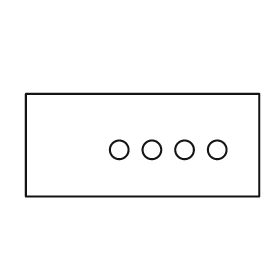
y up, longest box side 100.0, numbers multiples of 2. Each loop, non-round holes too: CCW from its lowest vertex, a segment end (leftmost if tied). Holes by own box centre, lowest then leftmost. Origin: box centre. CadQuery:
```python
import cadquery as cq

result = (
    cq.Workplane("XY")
    .moveTo(-50.0, -22.0)
    .lineTo(50.0, -22.0)
    .lineTo(50.0, 22.0)
    .lineTo(-50.0, 22.0)
    .close()
    .moveTo(-10.0, -2.0)
    .circle(4.0)
    .moveTo(4.0, -2.0)
    .circle(4.0)
    .moveTo(18.0, -2.0)
    .circle(4.0)
    .moveTo(32.0, -2.0)
    .circle(4.0)
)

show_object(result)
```